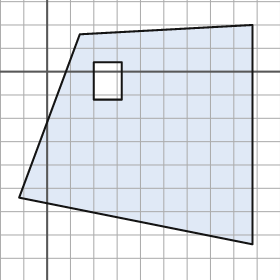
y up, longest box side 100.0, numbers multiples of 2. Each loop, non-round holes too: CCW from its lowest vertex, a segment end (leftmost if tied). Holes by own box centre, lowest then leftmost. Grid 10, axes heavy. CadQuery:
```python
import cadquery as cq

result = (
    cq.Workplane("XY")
    .moveTo(88.0, -74.0)
    .lineTo(88.0, 20.0)
    .lineTo(14.0, 16.0)
    .lineTo(-12.0, -54.0)
    .close()
    .moveTo(20.0, -12.0)
    .lineTo(32.0, -12.0)
    .lineTo(32.0, 4.0)
    .lineTo(20.0, 4.0)
    .close()
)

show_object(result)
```